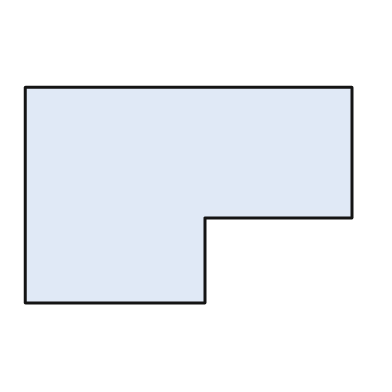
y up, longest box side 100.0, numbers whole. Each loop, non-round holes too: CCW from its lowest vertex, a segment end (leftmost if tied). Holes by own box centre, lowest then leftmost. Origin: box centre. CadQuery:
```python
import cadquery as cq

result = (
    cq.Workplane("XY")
    .moveTo(-50.0, -33.0)
    .lineTo(5.0, -33.0)
    .lineTo(5.0, -7.0)
    .lineTo(50.0, -7.0)
    .lineTo(50.0, 33.0)
    .lineTo(-50.0, 33.0)
    .close()
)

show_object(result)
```